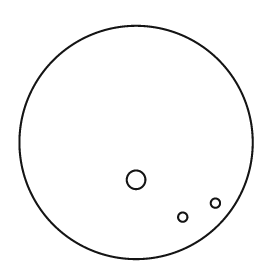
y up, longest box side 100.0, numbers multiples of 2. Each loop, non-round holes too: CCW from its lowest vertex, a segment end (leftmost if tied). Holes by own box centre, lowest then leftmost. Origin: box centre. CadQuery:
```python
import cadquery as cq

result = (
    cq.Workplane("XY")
    .moveTo(0.0, 0.0)
    .circle(50.0)
    .moveTo(20.0, -32.0)
    .circle(2.0)
    .moveTo(34.0, -26.0)
    .circle(2.0)
    .moveTo(0.0, -16.0)
    .circle(4.0)
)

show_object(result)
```